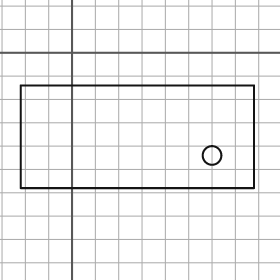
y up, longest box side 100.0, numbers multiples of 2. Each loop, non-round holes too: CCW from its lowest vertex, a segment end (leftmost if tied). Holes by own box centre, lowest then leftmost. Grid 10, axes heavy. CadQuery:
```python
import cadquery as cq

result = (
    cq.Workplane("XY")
    .moveTo(-22.0, -58.0)
    .lineTo(78.0, -58.0)
    .lineTo(78.0, -14.0)
    .lineTo(-22.0, -14.0)
    .close()
    .moveTo(60.0, -44.0)
    .circle(4.0)
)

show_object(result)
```